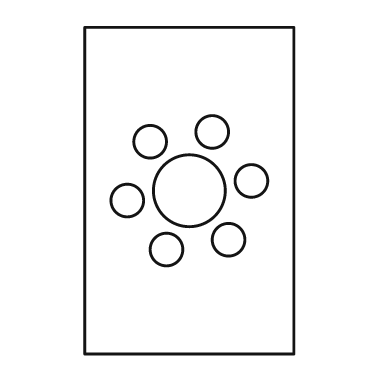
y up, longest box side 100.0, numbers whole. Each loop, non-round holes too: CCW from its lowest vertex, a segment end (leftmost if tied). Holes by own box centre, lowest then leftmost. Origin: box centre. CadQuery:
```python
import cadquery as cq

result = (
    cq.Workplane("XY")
    .moveTo(-32.0, -50.0)
    .lineTo(32.0, -50.0)
    .lineTo(32.0, 50.0)
    .lineTo(-32.0, 50.0)
    .close()
    .moveTo(-7.0, -18.0)
    .circle(5.0)
    .moveTo(12.0, -15.0)
    .circle(5.0)
    .moveTo(-19.0, -3.0)
    .circle(5.0)
    .moveTo(0.0, 0.0)
    .circle(11.0)
    .moveTo(19.0, 3.0)
    .circle(5.0)
    .moveTo(-12.0, 15.0)
    .circle(5.0)
    .moveTo(7.0, 18.0)
    .circle(5.0)
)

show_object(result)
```